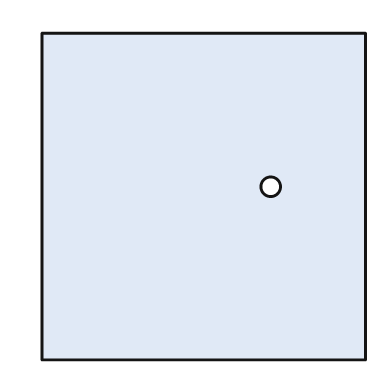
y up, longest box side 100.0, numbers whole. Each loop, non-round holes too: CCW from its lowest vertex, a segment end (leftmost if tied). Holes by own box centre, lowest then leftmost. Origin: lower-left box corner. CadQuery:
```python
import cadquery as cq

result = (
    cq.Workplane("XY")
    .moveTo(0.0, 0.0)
    .lineTo(99.0, 0.0)
    .lineTo(99.0, 100.0)
    .lineTo(0.0, 100.0)
    .close()
    .moveTo(70.0, 53.0)
    .circle(3.0)
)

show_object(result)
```